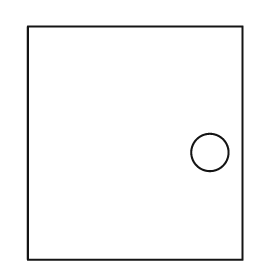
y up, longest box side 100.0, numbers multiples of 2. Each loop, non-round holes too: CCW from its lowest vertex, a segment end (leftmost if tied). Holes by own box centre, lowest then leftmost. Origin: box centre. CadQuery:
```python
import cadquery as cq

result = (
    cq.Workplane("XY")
    .moveTo(-46.0, -50.0)
    .lineTo(46.0, -50.0)
    .lineTo(46.0, 50.0)
    .lineTo(-46.0, 50.0)
    .close()
    .moveTo(32.0, -4.0)
    .circle(8.0)
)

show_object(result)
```